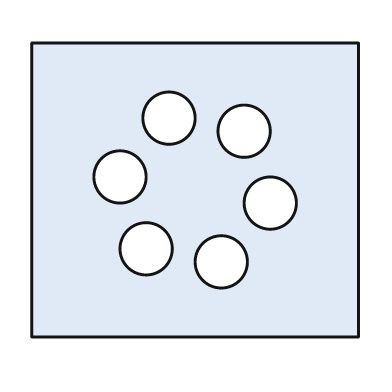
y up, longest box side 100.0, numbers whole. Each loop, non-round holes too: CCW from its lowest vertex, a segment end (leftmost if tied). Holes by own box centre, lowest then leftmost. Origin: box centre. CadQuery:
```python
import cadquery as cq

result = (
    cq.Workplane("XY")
    .moveTo(-50.0, -45.0)
    .lineTo(50.0, -45.0)
    .lineTo(50.0, 45.0)
    .lineTo(-50.0, 45.0)
    .close()
    .moveTo(8.0, -22.0)
    .circle(8.0)
    .moveTo(-15.0, -18.0)
    .circle(8.0)
    .moveTo(23.0, -4.0)
    .circle(8.0)
    .moveTo(-23.0, 4.0)
    .circle(8.0)
    .moveTo(15.0, 18.0)
    .circle(8.0)
    .moveTo(-8.0, 22.0)
    .circle(8.0)
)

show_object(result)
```